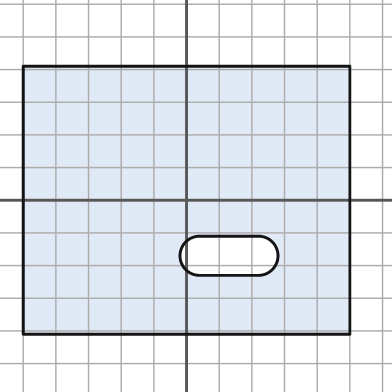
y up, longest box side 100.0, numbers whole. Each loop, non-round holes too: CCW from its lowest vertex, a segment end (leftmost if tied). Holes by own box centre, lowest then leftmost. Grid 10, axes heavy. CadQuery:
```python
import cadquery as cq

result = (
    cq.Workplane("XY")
    .moveTo(-50.0, -41.0)
    .lineTo(50.0, -41.0)
    .lineTo(50.0, 41.0)
    .lineTo(-50.0, 41.0)
    .close()
    .moveTo(4.0, -23.0)
    .lineTo(22.0, -23.0)
    .threePointArc((28.0, -17.0), (22.0, -11.0))
    .lineTo(4.0, -11.0)
    .threePointArc((-2.0, -17.0), (4.0, -23.0))
    .close()
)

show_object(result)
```